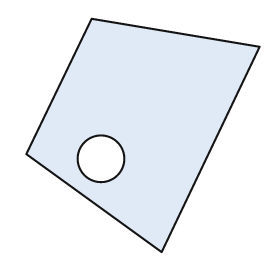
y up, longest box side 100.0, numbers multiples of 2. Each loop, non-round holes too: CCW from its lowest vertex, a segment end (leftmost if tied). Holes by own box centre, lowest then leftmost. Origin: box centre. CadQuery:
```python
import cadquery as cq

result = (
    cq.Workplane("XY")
    .moveTo(8.0, -50.0)
    .lineTo(50.0, 38.0)
    .lineTo(-22.0, 50.0)
    .lineTo(-50.0, -8.0)
    .close()
    .moveTo(-18.0, -10.0)
    .circle(10.0)
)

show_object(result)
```